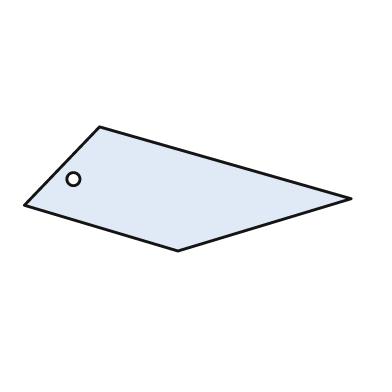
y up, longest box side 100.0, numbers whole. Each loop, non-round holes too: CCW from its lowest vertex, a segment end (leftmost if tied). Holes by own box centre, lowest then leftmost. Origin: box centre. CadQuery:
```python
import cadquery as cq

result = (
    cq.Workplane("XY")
    .moveTo(-3.0, -19.0)
    .lineTo(50.0, -3.0)
    .lineTo(-27.0, 19.0)
    .lineTo(-50.0, -5.0)
    .close()
    .moveTo(-35.0, 3.0)
    .circle(2.0)
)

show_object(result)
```